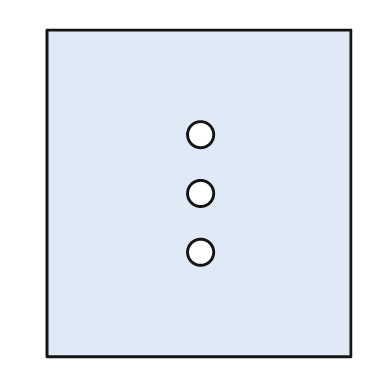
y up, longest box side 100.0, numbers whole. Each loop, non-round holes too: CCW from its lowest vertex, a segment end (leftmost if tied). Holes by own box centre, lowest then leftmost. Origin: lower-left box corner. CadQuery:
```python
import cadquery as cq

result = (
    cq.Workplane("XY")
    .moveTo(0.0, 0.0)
    .lineTo(93.0, 0.0)
    .lineTo(93.0, 100.0)
    .lineTo(0.0, 100.0)
    .close()
    .moveTo(47.0, 32.0)
    .circle(4.0)
    .moveTo(47.0, 50.0)
    .circle(4.0)
    .moveTo(47.0, 68.0)
    .circle(4.0)
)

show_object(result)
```